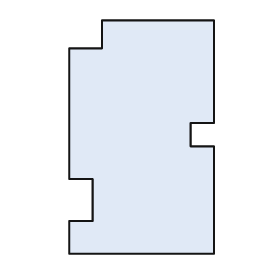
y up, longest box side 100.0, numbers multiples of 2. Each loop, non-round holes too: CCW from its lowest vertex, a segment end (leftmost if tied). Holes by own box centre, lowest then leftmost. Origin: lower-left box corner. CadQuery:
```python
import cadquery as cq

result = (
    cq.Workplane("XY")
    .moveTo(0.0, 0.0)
    .lineTo(62.0, 0.0)
    .lineTo(62.0, 46.0)
    .lineTo(52.0, 46.0)
    .lineTo(52.0, 56.0)
    .lineTo(62.0, 56.0)
    .lineTo(62.0, 100.0)
    .lineTo(14.0, 100.0)
    .lineTo(14.0, 88.0)
    .lineTo(0.0, 88.0)
    .lineTo(0.0, 32.0)
    .lineTo(10.0, 32.0)
    .lineTo(10.0, 14.0)
    .lineTo(0.0, 14.0)
    .close()
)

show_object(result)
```